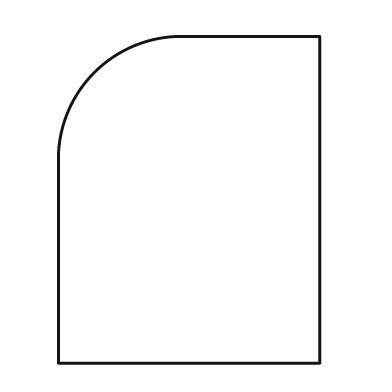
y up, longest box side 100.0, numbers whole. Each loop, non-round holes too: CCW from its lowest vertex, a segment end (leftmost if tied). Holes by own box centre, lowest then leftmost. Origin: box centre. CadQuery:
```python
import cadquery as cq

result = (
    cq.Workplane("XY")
    .moveTo(-40.0, -50.0)
    .lineTo(40.0, -50.0)
    .lineTo(40.0, 50.0)
    .lineTo(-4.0, 50.0)
    .threePointArc((-29.0, 39.0), (-40.0, 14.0))
    .close()
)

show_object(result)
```